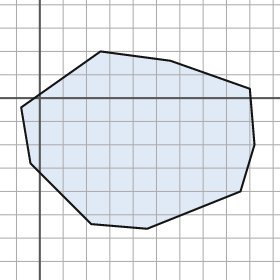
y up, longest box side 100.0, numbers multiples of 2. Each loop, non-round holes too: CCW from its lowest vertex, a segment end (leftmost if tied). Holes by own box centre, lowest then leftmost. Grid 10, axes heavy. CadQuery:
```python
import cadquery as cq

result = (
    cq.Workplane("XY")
    .moveTo(46.0, -56.0)
    .lineTo(86.0, -40.0)
    .lineTo(92.0, -20.0)
    .lineTo(90.0, 4.0)
    .lineTo(56.0, 16.0)
    .lineTo(26.0, 20.0)
    .lineTo(-8.0, -4.0)
    .lineTo(-4.0, -28.0)
    .lineTo(22.0, -54.0)
    .close()
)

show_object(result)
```